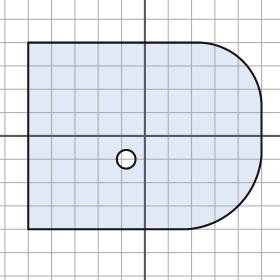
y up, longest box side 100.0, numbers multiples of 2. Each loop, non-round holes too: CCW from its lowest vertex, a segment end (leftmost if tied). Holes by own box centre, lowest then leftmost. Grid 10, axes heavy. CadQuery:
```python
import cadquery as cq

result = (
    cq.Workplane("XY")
    .moveTo(-50.0, -40.0)
    .lineTo(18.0, -40.0)
    .threePointArc((40.0, -30.0), (50.0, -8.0))
    .lineTo(50.0, 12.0)
    .threePointArc((42.0, 32.0), (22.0, 40.0))
    .lineTo(-50.0, 40.0)
    .close()
    .moveTo(-8.0, -10.0)
    .circle(4.0)
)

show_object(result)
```